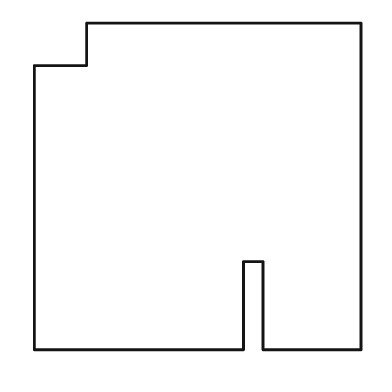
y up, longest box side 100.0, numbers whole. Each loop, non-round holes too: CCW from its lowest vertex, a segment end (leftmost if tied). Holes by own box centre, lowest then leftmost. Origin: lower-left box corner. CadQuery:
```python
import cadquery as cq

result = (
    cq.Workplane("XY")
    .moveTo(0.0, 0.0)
    .lineTo(64.0, 0.0)
    .lineTo(64.0, 27.0)
    .lineTo(70.0, 27.0)
    .lineTo(70.0, 0.0)
    .lineTo(100.0, 0.0)
    .lineTo(100.0, 100.0)
    .lineTo(16.0, 100.0)
    .lineTo(16.0, 87.0)
    .lineTo(0.0, 87.0)
    .close()
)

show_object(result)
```